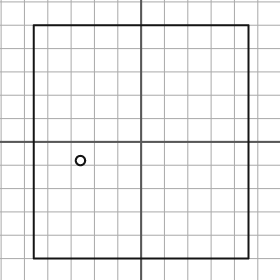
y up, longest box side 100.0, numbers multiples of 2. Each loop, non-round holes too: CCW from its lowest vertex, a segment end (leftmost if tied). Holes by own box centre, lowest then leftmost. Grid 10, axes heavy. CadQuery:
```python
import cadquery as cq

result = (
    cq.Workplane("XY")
    .moveTo(-46.0, -50.0)
    .lineTo(46.0, -50.0)
    .lineTo(46.0, 50.0)
    .lineTo(-46.0, 50.0)
    .close()
    .moveTo(-26.0, -8.0)
    .circle(2.0)
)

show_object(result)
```